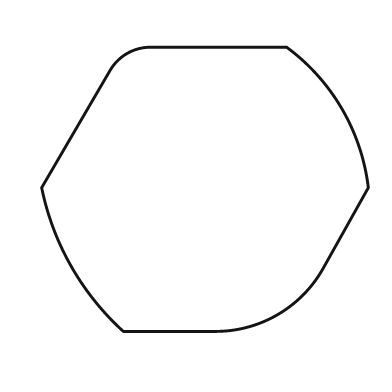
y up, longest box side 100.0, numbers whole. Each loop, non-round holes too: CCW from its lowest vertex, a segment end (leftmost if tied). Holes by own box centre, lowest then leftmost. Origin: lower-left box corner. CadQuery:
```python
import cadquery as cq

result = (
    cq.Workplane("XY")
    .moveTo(25.0, 0.0)
    .lineTo(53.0, 0.0)
    .threePointArc((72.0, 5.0), (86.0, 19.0))
    .lineTo(100.0, 44.0)
    .threePointArc((92.0, 68.0), (75.0, 87.0))
    .lineTo(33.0, 87.0)
    .threePointArc((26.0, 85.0), (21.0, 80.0))
    .lineTo(0.0, 44.0)
    .threePointArc((9.0, 20.0), (25.0, 0.0))
    .close()
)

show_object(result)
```